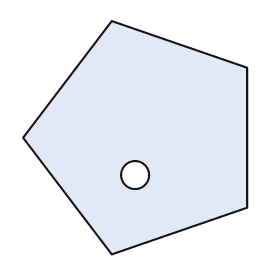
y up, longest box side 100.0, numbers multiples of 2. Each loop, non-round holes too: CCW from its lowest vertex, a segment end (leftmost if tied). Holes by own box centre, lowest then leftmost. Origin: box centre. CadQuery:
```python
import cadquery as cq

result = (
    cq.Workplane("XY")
    .moveTo(-10.0, -50.0)
    .lineTo(48.0, -30.0)
    .lineTo(48.0, 30.0)
    .lineTo(-10.0, 50.0)
    .lineTo(-48.0, 0.0)
    .close()
    .moveTo(0.0, -16.0)
    .circle(6.0)
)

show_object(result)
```